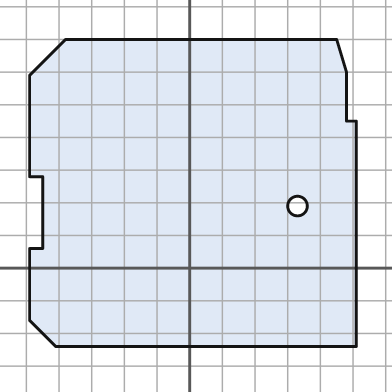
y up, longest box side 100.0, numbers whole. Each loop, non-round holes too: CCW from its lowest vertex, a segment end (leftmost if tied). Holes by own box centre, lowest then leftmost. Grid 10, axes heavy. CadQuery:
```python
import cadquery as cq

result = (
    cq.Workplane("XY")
    .moveTo(-41.0, -24.0)
    .lineTo(51.0, -24.0)
    .lineTo(51.0, 45.0)
    .lineTo(48.0, 45.0)
    .lineTo(48.0, 60.0)
    .lineTo(45.0, 70.0)
    .lineTo(-38.0, 70.0)
    .lineTo(-49.0, 59.0)
    .lineTo(-49.0, 28.0)
    .lineTo(-45.0, 28.0)
    .lineTo(-45.0, 6.0)
    .lineTo(-49.0, 6.0)
    .lineTo(-49.0, -16.0)
    .close()
    .moveTo(33.0, 19.0)
    .circle(3.0)
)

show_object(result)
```